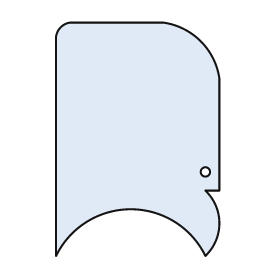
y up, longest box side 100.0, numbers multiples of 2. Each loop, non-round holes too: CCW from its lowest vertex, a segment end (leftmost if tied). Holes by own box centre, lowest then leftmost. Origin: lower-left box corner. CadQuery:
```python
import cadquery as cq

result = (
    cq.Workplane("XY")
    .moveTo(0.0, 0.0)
    .threePointArc((32.0, 20.0), (64.0, 0.0))
    .threePointArc((70.0, 14.0), (64.0, 28.0))
    .lineTo(70.0, 28.0)
    .lineTo(70.0, 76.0)
    .threePointArc((62.0, 92.0), (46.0, 100.0))
    .lineTo(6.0, 100.0)
    .threePointArc((2.0, 98.0), (0.0, 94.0))
    .close()
    .moveTo(64.0, 36.0)
    .circle(2.0)
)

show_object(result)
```